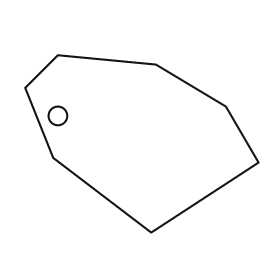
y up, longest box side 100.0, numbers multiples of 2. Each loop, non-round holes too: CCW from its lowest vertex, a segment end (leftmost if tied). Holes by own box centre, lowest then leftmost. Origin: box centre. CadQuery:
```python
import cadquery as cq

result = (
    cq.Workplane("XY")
    .moveTo(4.0, -38.0)
    .lineTo(50.0, -8.0)
    .lineTo(36.0, 16.0)
    .lineTo(6.0, 34.0)
    .lineTo(-36.0, 38.0)
    .lineTo(-50.0, 24.0)
    .lineTo(-38.0, -6.0)
    .close()
    .moveTo(-36.0, 12.0)
    .circle(4.0)
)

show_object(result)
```